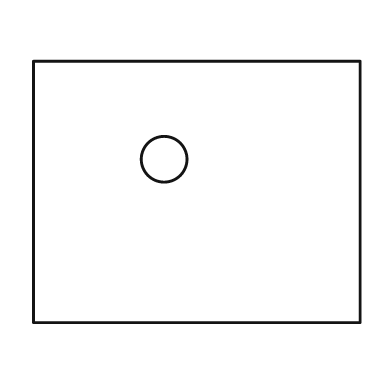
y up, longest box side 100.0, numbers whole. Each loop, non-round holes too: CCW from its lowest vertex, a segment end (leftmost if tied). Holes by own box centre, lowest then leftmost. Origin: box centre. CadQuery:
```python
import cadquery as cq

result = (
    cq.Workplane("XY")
    .moveTo(-50.0, -40.0)
    .lineTo(50.0, -40.0)
    .lineTo(50.0, 40.0)
    .lineTo(-50.0, 40.0)
    .close()
    .moveTo(-10.0, 10.0)
    .circle(7.0)
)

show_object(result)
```